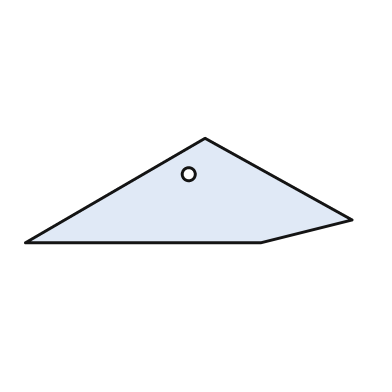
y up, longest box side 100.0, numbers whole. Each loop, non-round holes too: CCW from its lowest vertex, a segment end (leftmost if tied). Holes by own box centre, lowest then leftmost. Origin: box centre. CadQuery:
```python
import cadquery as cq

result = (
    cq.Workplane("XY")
    .moveTo(-50.0, -16.0)
    .lineTo(22.0, -16.0)
    .lineTo(50.0, -9.0)
    .lineTo(5.0, 16.0)
    .close()
    .moveTo(0.0, 5.0)
    .circle(2.0)
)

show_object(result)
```